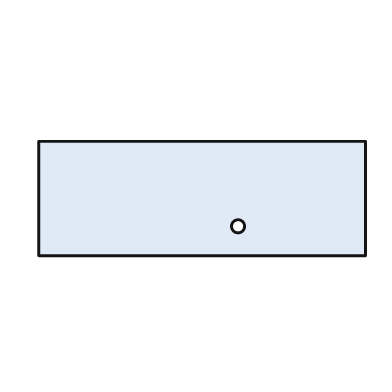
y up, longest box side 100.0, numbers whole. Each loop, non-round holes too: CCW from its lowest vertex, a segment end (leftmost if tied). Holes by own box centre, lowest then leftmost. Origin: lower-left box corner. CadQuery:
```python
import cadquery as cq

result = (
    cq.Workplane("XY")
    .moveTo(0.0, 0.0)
    .lineTo(100.0, 0.0)
    .lineTo(100.0, 35.0)
    .lineTo(0.0, 35.0)
    .close()
    .moveTo(61.0, 9.0)
    .circle(2.0)
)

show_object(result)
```